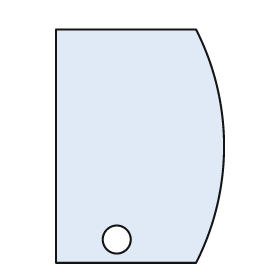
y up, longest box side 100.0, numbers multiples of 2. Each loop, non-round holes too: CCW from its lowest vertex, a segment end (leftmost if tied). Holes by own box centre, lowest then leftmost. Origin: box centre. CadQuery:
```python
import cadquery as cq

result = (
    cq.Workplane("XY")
    .moveTo(-36.0, -50.0)
    .lineTo(24.0, -50.0)
    .threePointArc((36.0, 0.0), (24.0, 50.0))
    .lineTo(-36.0, 50.0)
    .close()
    .moveTo(-10.0, -40.0)
    .circle(6.0)
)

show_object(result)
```